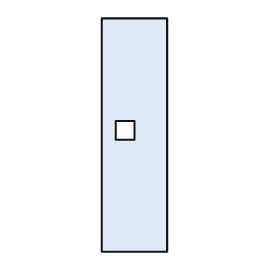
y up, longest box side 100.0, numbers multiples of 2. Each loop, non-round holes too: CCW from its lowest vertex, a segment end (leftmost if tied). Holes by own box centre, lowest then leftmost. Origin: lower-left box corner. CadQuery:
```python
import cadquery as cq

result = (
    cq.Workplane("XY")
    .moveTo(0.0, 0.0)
    .lineTo(28.0, 0.0)
    .lineTo(28.0, 100.0)
    .lineTo(0.0, 100.0)
    .close()
    .moveTo(6.0, 48.0)
    .lineTo(14.0, 48.0)
    .lineTo(14.0, 56.0)
    .lineTo(6.0, 56.0)
    .close()
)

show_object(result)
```